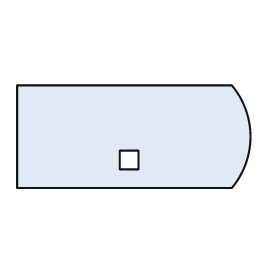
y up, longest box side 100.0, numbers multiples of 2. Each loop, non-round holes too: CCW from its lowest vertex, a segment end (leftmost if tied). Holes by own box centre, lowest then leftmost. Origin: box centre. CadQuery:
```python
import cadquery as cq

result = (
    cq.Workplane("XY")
    .moveTo(-50.0, -22.0)
    .lineTo(42.0, -22.0)
    .threePointArc((50.0, 0.0), (42.0, 22.0))
    .lineTo(-50.0, 22.0)
    .close()
    .moveTo(-6.0, -14.0)
    .lineTo(2.0, -14.0)
    .lineTo(2.0, -6.0)
    .lineTo(-6.0, -6.0)
    .close()
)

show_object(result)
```